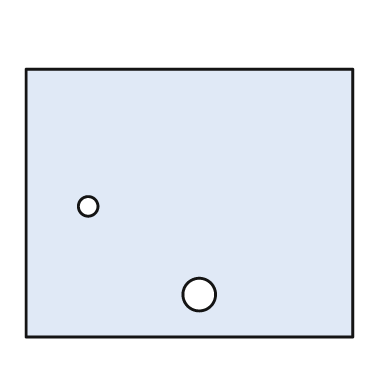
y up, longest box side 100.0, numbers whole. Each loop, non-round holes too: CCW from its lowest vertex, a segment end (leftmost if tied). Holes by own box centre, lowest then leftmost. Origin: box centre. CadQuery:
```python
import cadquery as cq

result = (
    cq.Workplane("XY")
    .moveTo(-50.0, -41.0)
    .lineTo(50.0, -41.0)
    .lineTo(50.0, 41.0)
    .lineTo(-50.0, 41.0)
    .close()
    .moveTo(3.0, -28.0)
    .circle(5.0)
    .moveTo(-31.0, -1.0)
    .circle(3.0)
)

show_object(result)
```